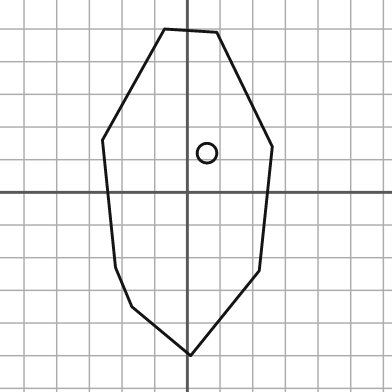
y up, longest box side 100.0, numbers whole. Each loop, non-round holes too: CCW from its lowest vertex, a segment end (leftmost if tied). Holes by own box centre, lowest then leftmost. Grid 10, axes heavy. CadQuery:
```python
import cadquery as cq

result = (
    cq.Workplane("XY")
    .moveTo(1.0, -50.0)
    .lineTo(22.0, -24.0)
    .lineTo(26.0, 14.0)
    .lineTo(9.0, 49.0)
    .lineTo(-7.0, 50.0)
    .lineTo(-26.0, 16.0)
    .lineTo(-22.0, -23.0)
    .lineTo(-17.0, -35.0)
    .close()
    .moveTo(6.0, 12.0)
    .circle(3.0)
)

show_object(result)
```